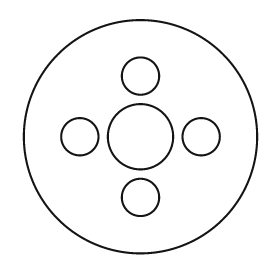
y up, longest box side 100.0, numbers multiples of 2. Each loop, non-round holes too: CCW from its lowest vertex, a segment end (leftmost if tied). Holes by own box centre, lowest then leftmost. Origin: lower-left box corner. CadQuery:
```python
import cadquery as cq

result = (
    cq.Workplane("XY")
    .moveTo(50.0, 50.0)
    .circle(50.0)
    .moveTo(50.0, 24.0)
    .circle(8.0)
    .moveTo(24.0, 50.0)
    .circle(8.0)
    .moveTo(50.0, 50.0)
    .circle(14.0)
    .moveTo(76.0, 50.0)
    .circle(8.0)
    .moveTo(50.0, 76.0)
    .circle(8.0)
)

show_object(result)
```